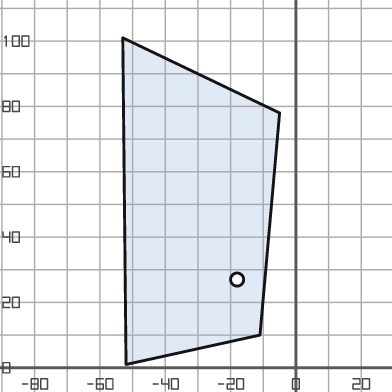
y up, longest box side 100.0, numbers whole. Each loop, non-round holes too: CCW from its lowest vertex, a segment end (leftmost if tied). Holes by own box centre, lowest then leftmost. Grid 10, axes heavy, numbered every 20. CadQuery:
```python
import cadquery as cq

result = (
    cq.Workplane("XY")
    .moveTo(-52.0, 1.0)
    .lineTo(-11.0, 10.0)
    .lineTo(-5.0, 78.0)
    .lineTo(-53.0, 101.0)
    .close()
    .moveTo(-18.0, 27.0)
    .circle(2.0)
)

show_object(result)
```